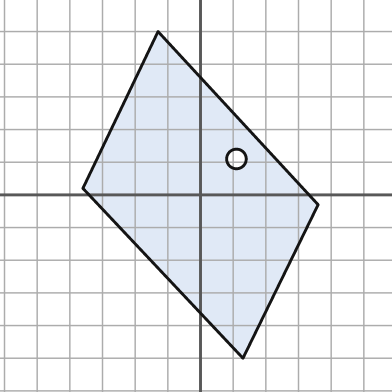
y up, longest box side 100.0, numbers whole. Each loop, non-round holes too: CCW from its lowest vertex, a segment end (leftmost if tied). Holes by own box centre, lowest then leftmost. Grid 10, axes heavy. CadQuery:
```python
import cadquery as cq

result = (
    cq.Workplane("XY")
    .moveTo(13.0, -50.0)
    .lineTo(36.0, -3.0)
    .lineTo(-13.0, 50.0)
    .lineTo(-36.0, 2.0)
    .close()
    .moveTo(11.0, 11.0)
    .circle(3.0)
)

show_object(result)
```